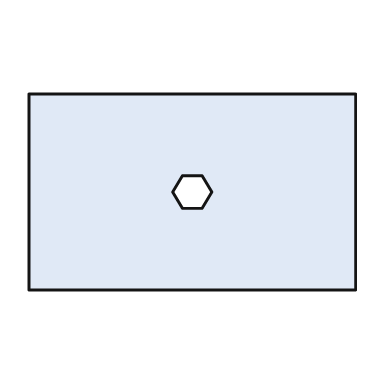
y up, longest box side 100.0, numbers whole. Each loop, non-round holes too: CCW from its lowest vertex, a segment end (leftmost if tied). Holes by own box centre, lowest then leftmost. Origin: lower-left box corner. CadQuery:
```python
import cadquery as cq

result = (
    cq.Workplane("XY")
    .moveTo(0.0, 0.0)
    .lineTo(100.0, 0.0)
    .lineTo(100.0, 60.0)
    .lineTo(0.0, 60.0)
    .close()
    .moveTo(47.0, 25.0)
    .lineTo(53.0, 25.0)
    .lineTo(56.0, 30.0)
    .lineTo(53.0, 35.0)
    .lineTo(47.0, 35.0)
    .lineTo(44.0, 30.0)
    .close()
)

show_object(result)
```